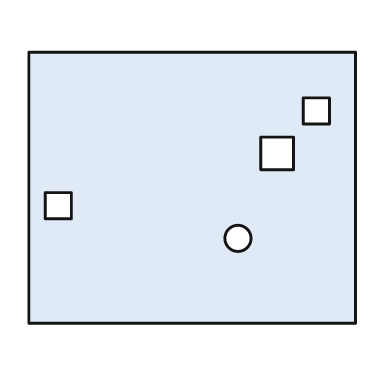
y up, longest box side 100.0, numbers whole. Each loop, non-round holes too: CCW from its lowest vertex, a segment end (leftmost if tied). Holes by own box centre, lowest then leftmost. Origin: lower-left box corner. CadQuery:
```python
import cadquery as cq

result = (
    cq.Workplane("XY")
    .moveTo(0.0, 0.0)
    .lineTo(100.0, 0.0)
    .lineTo(100.0, 83.0)
    .lineTo(0.0, 83.0)
    .close()
    .moveTo(64.0, 26.0)
    .circle(4.0)
    .moveTo(5.0, 32.0)
    .lineTo(13.0, 32.0)
    .lineTo(13.0, 40.0)
    .lineTo(5.0, 40.0)
    .close()
    .moveTo(71.0, 47.0)
    .lineTo(81.0, 47.0)
    .lineTo(81.0, 57.0)
    .lineTo(71.0, 57.0)
    .close()
    .moveTo(84.0, 61.0)
    .lineTo(92.0, 61.0)
    .lineTo(92.0, 69.0)
    .lineTo(84.0, 69.0)
    .close()
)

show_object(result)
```